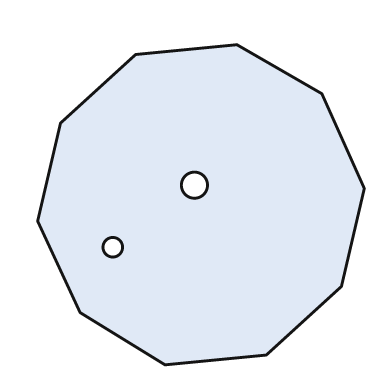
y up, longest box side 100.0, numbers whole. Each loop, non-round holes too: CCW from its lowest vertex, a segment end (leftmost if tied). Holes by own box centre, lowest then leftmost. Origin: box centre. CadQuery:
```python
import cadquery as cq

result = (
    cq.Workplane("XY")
    .moveTo(-11.0, -49.0)
    .lineTo(20.0, -46.0)
    .lineTo(43.0, -25.0)
    .lineTo(50.0, 5.0)
    .lineTo(37.0, 34.0)
    .lineTo(11.0, 49.0)
    .lineTo(-20.0, 46.0)
    .lineTo(-43.0, 25.0)
    .lineTo(-50.0, -5.0)
    .lineTo(-37.0, -33.0)
    .close()
    .moveTo(-27.0, -13.0)
    .circle(3.0)
    .moveTo(-2.0, 6.0)
    .circle(4.0)
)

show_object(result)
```